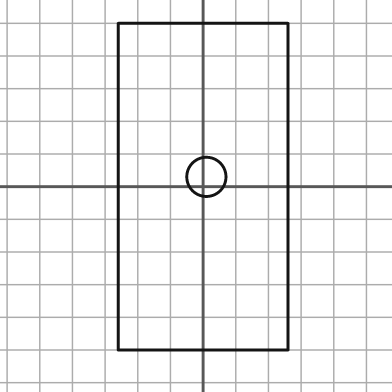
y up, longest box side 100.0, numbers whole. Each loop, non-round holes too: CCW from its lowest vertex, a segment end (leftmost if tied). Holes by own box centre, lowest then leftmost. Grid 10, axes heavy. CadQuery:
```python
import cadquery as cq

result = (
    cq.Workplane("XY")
    .moveTo(-26.0, -50.0)
    .lineTo(26.0, -50.0)
    .lineTo(26.0, 50.0)
    .lineTo(-26.0, 50.0)
    .close()
    .moveTo(1.0, 3.0)
    .circle(6.0)
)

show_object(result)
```